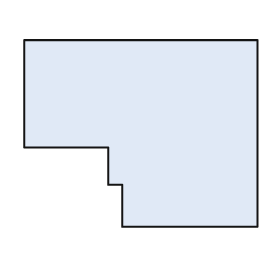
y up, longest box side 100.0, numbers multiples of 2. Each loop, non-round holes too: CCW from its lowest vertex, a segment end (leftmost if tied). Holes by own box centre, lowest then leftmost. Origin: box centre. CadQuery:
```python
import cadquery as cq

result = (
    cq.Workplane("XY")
    .moveTo(-8.0, -40.0)
    .lineTo(50.0, -40.0)
    .lineTo(50.0, 40.0)
    .lineTo(-50.0, 40.0)
    .lineTo(-50.0, -6.0)
    .lineTo(-14.0, -6.0)
    .lineTo(-14.0, -22.0)
    .lineTo(-8.0, -22.0)
    .close()
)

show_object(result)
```